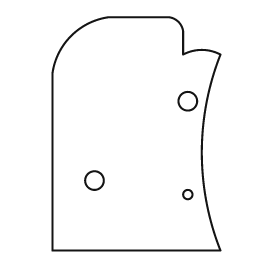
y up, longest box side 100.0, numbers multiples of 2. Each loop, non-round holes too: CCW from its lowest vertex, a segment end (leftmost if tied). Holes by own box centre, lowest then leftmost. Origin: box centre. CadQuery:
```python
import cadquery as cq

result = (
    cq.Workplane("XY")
    .moveTo(-36.0, -50.0)
    .lineTo(36.0, -50.0)
    .threePointArc((28.0, -8.0), (36.0, 34.0))
    .threePointArc((28.0, 36.0), (20.0, 34.0))
    .lineTo(20.0, 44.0)
    .threePointArc((18.0, 48.0), (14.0, 50.0))
    .lineTo(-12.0, 50.0)
    .threePointArc((-28.0, 42.0), (-36.0, 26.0))
    .close()
    .moveTo(22.0, -26.0)
    .circle(2.0)
    .moveTo(-18.0, -20.0)
    .circle(4.0)
    .moveTo(22.0, 14.0)
    .circle(4.0)
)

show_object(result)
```